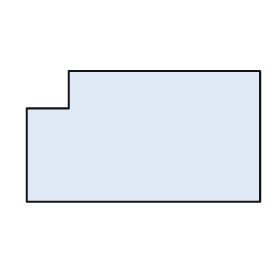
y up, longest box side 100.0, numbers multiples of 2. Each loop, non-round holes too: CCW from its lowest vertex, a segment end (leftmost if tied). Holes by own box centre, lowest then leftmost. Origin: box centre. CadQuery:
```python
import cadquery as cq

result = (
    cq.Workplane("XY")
    .moveTo(-50.0, -28.0)
    .lineTo(50.0, -28.0)
    .lineTo(50.0, 28.0)
    .lineTo(-32.0, 28.0)
    .lineTo(-32.0, 12.0)
    .lineTo(-50.0, 12.0)
    .close()
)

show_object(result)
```